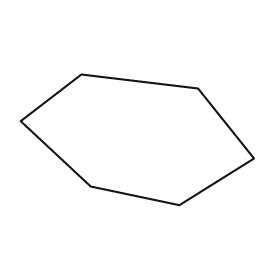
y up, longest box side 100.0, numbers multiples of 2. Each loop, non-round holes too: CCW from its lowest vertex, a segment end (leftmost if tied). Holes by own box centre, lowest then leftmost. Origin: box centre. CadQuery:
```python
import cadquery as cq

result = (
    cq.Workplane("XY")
    .moveTo(18.0, -28.0)
    .lineTo(50.0, -8.0)
    .lineTo(26.0, 22.0)
    .lineTo(-24.0, 28.0)
    .lineTo(-50.0, 8.0)
    .lineTo(-20.0, -20.0)
    .close()
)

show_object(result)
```